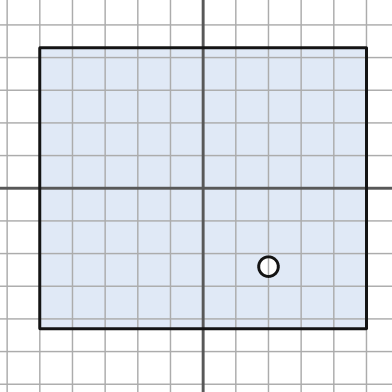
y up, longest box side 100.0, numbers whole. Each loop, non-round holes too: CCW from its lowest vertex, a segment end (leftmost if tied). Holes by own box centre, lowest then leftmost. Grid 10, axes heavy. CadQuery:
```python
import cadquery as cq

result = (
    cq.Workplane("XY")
    .moveTo(-50.0, -43.0)
    .lineTo(50.0, -43.0)
    .lineTo(50.0, 43.0)
    .lineTo(-50.0, 43.0)
    .close()
    .moveTo(20.0, -24.0)
    .circle(3.0)
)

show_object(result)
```